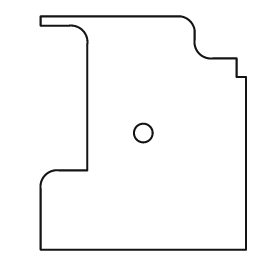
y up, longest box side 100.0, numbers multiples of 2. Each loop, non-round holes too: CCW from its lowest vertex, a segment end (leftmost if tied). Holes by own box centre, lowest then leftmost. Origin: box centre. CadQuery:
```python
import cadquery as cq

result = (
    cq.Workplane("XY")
    .moveTo(-44.0, -50.0)
    .lineTo(44.0, -50.0)
    .lineTo(44.0, 24.0)
    .lineTo(40.0, 24.0)
    .lineTo(40.0, 32.0)
    .lineTo(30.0, 32.0)
    .threePointArc((24.0, 34.0), (22.0, 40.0))
    .lineTo(22.0, 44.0)
    .threePointArc((20.0, 48.0), (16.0, 50.0))
    .lineTo(-44.0, 50.0)
    .lineTo(-44.0, 46.0)
    .lineTo(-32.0, 46.0)
    .threePointArc((-26.0, 44.0), (-24.0, 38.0))
    .lineTo(-24.0, -16.0)
    .lineTo(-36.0, -16.0)
    .threePointArc((-42.0, -18.0), (-44.0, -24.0))
    .close()
    .moveTo(0.0, 0.0)
    .circle(4.0)
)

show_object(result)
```